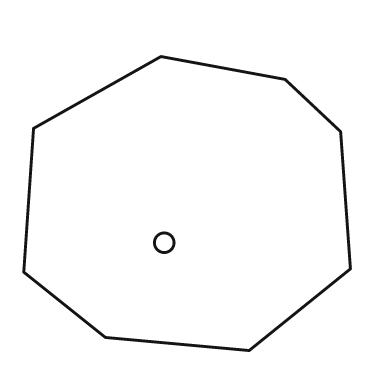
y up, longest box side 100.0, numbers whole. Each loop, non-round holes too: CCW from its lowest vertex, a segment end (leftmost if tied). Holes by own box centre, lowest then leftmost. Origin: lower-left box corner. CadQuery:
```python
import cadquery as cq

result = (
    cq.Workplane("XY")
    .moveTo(69.0, 0.0)
    .lineTo(100.0, 25.0)
    .lineTo(97.0, 67.0)
    .lineTo(80.0, 83.0)
    .lineTo(42.0, 90.0)
    .lineTo(3.0, 68.0)
    .lineTo(0.0, 24.0)
    .lineTo(25.0, 4.0)
    .close()
    .moveTo(43.0, 33.0)
    .circle(3.0)
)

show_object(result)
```